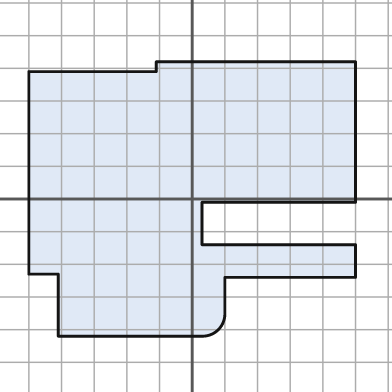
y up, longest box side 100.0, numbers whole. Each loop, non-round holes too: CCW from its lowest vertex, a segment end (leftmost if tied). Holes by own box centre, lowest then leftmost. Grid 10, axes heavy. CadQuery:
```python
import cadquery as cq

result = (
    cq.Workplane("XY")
    .moveTo(-41.0, -42.0)
    .lineTo(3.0, -42.0)
    .threePointArc((8.0, -40.0), (10.0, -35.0))
    .lineTo(10.0, -24.0)
    .lineTo(50.0, -24.0)
    .lineTo(50.0, -14.0)
    .lineTo(3.0, -14.0)
    .lineTo(3.0, -1.0)
    .lineTo(50.0, -1.0)
    .lineTo(50.0, 42.0)
    .lineTo(-11.0, 42.0)
    .lineTo(-11.0, 39.0)
    .lineTo(-50.0, 39.0)
    .lineTo(-50.0, -23.0)
    .lineTo(-41.0, -23.0)
    .close()
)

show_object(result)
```